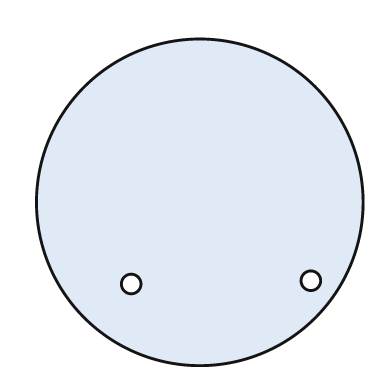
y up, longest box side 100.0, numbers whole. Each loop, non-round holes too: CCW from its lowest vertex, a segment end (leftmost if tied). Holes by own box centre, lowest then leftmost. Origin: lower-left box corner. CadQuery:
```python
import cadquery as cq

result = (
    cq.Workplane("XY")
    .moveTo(50.0, 50.0)
    .circle(50.0)
    .moveTo(29.0, 25.0)
    .circle(3.0)
    .moveTo(84.0, 26.0)
    .circle(3.0)
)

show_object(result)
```